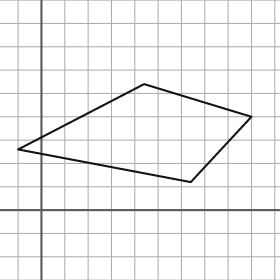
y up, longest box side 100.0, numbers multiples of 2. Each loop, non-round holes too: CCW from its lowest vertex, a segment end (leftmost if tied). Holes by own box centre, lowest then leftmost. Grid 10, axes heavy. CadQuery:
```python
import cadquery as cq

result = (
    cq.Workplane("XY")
    .moveTo(64.0, 12.0)
    .lineTo(90.0, 40.0)
    .lineTo(44.0, 54.0)
    .lineTo(-10.0, 26.0)
    .close()
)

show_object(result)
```